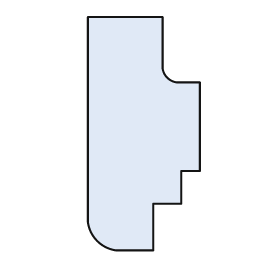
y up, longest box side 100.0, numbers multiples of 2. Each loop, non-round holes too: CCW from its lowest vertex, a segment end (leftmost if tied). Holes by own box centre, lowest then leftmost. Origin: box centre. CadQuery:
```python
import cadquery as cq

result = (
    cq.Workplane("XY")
    .moveTo(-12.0, -50.0)
    .lineTo(4.0, -50.0)
    .lineTo(4.0, -30.0)
    .lineTo(16.0, -30.0)
    .lineTo(16.0, -16.0)
    .lineTo(24.0, -16.0)
    .lineTo(24.0, 22.0)
    .lineTo(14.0, 22.0)
    .threePointArc((10.0, 24.0), (8.0, 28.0))
    .lineTo(8.0, 50.0)
    .lineTo(-24.0, 50.0)
    .lineTo(-24.0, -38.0)
    .threePointArc((-20.0, -46.0), (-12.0, -50.0))
    .close()
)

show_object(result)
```